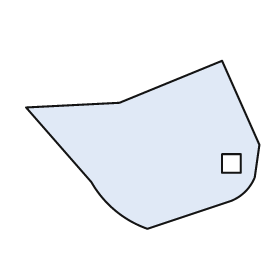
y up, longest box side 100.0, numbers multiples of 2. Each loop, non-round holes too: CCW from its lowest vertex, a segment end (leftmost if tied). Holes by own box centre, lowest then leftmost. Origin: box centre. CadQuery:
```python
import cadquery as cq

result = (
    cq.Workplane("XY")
    .moveTo(2.0, -36.0)
    .lineTo(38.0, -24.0)
    .threePointArc((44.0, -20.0), (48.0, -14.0))
    .lineTo(50.0, 0.0)
    .lineTo(34.0, 36.0)
    .lineTo(-10.0, 18.0)
    .lineTo(-50.0, 16.0)
    .lineTo(-22.0, -16.0)
    .threePointArc((-12.0, -28.0), (2.0, -36.0))
    .close()
    .moveTo(34.0, -12.0)
    .lineTo(42.0, -12.0)
    .lineTo(42.0, -4.0)
    .lineTo(34.0, -4.0)
    .close()
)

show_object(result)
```